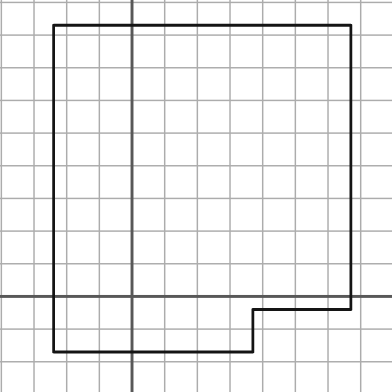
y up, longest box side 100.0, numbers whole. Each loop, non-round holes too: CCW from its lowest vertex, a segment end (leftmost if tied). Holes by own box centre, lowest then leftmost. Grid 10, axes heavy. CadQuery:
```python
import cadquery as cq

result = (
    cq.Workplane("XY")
    .moveTo(-24.0, -17.0)
    .lineTo(37.0, -17.0)
    .lineTo(37.0, -4.0)
    .lineTo(67.0, -4.0)
    .lineTo(67.0, 83.0)
    .lineTo(-24.0, 83.0)
    .close()
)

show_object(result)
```